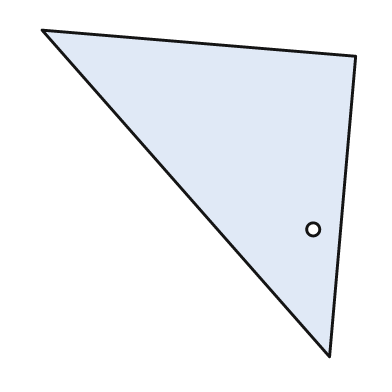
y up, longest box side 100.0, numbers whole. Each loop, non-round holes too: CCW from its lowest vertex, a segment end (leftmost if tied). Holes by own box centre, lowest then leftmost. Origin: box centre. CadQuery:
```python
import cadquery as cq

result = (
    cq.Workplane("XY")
    .moveTo(40.0, -50.0)
    .lineTo(48.0, 42.0)
    .lineTo(-48.0, 50.0)
    .close()
    .moveTo(35.0, -11.0)
    .circle(2.0)
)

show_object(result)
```